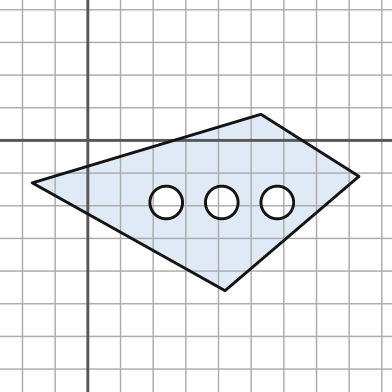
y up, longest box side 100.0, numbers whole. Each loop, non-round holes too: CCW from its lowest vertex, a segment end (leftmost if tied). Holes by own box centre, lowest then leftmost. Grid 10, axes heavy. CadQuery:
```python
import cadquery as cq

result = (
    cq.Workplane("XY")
    .moveTo(42.0, -46.0)
    .lineTo(83.0, -11.0)
    .lineTo(53.0, 8.0)
    .lineTo(-17.0, -13.0)
    .close()
    .moveTo(24.0, -19.0)
    .circle(5.0)
    .moveTo(41.0, -19.0)
    .circle(5.0)
    .moveTo(58.0, -19.0)
    .circle(5.0)
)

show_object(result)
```